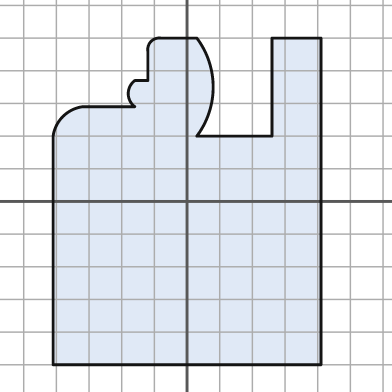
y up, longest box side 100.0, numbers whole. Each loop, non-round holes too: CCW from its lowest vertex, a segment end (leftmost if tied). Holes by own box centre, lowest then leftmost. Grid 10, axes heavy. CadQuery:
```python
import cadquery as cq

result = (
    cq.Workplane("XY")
    .moveTo(-41.0, -50.0)
    .lineTo(41.0, -50.0)
    .lineTo(41.0, 50.0)
    .lineTo(26.0, 50.0)
    .lineTo(26.0, 20.0)
    .lineTo(3.0, 20.0)
    .threePointArc((8.0, 35.0), (3.0, 50.0))
    .lineTo(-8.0, 50.0)
    .threePointArc((-11.0, 49.0), (-12.0, 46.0))
    .lineTo(-12.0, 37.0)
    .lineTo(-16.0, 37.0)
    .threePointArc((-18.0, 33.0), (-16.0, 29.0))
    .lineTo(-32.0, 29.0)
    .threePointArc((-38.0, 26.0), (-41.0, 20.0))
    .close()
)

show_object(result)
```